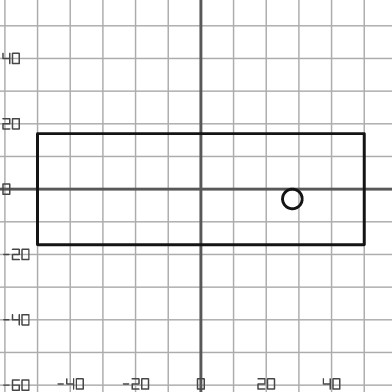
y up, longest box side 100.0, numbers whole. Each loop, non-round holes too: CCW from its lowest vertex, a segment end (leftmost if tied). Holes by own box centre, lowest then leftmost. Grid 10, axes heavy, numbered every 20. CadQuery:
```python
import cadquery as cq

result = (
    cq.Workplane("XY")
    .moveTo(-50.0, -17.0)
    .lineTo(50.0, -17.0)
    .lineTo(50.0, 17.0)
    .lineTo(-50.0, 17.0)
    .close()
    .moveTo(28.0, -3.0)
    .circle(3.0)
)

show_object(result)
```